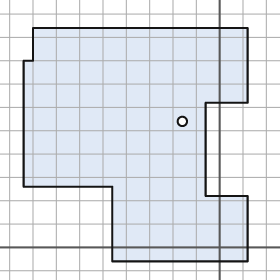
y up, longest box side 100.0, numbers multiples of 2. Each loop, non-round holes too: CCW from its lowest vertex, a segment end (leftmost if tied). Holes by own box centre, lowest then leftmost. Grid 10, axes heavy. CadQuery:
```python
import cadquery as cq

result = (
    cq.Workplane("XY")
    .moveTo(-46.0, -6.0)
    .lineTo(12.0, -6.0)
    .lineTo(12.0, 22.0)
    .lineTo(-6.0, 22.0)
    .lineTo(-6.0, 62.0)
    .lineTo(12.0, 62.0)
    .lineTo(12.0, 94.0)
    .lineTo(-80.0, 94.0)
    .lineTo(-80.0, 80.0)
    .lineTo(-84.0, 80.0)
    .lineTo(-84.0, 26.0)
    .lineTo(-46.0, 26.0)
    .close()
    .moveTo(-16.0, 54.0)
    .circle(2.0)
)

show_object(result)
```